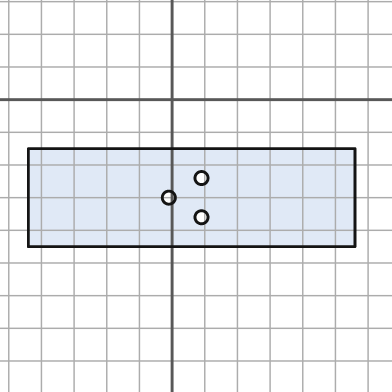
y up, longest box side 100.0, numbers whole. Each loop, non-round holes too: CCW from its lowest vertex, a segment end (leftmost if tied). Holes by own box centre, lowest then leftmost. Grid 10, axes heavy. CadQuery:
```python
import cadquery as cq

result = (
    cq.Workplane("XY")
    .moveTo(-44.0, -45.0)
    .lineTo(56.0, -45.0)
    .lineTo(56.0, -15.0)
    .lineTo(-44.0, -15.0)
    .close()
    .moveTo(9.0, -36.0)
    .circle(2.0)
    .moveTo(-1.0, -30.0)
    .circle(2.0)
    .moveTo(9.0, -24.0)
    .circle(2.0)
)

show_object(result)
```